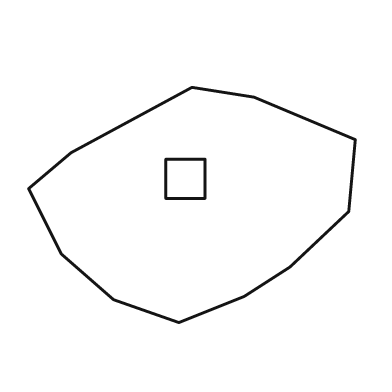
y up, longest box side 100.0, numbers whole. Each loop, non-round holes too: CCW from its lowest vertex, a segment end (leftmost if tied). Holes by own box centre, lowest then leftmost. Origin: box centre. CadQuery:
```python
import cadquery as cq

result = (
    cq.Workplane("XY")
    .moveTo(-4.0, -36.0)
    .lineTo(16.0, -28.0)
    .lineTo(30.0, -19.0)
    .lineTo(48.0, -2.0)
    .lineTo(50.0, 20.0)
    .lineTo(19.0, 33.0)
    .lineTo(0.0, 36.0)
    .lineTo(-37.0, 16.0)
    .lineTo(-50.0, 5.0)
    .lineTo(-40.0, -15.0)
    .lineTo(-24.0, -29.0)
    .close()
    .moveTo(-8.0, 2.0)
    .lineTo(4.0, 2.0)
    .lineTo(4.0, 14.0)
    .lineTo(-8.0, 14.0)
    .close()
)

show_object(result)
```